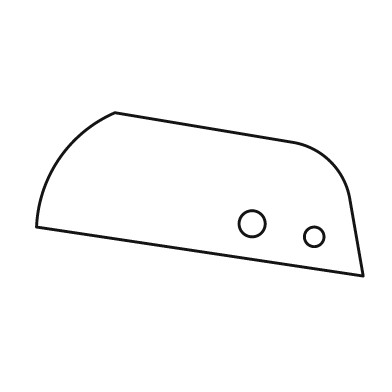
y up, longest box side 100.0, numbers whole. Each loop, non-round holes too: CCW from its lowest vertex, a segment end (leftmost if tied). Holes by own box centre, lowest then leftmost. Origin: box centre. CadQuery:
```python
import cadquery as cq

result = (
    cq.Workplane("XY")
    .moveTo(50.0, -25.0)
    .lineTo(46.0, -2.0)
    .threePointArc((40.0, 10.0), (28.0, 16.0))
    .lineTo(-26.0, 25.0)
    .threePointArc((-43.0, 11.0), (-50.0, -10.0))
    .close()
    .moveTo(35.0, -13.0)
    .circle(3.0)
    .moveTo(16.0, -9.0)
    .circle(4.0)
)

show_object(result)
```